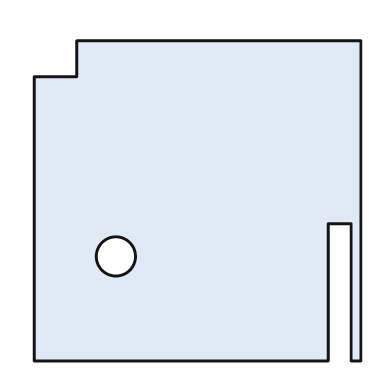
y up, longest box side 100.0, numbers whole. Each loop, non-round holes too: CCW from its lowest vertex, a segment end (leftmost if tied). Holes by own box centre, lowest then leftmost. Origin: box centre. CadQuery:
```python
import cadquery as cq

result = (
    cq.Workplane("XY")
    .moveTo(-50.0, -49.0)
    .lineTo(40.0, -49.0)
    .lineTo(40.0, -7.0)
    .lineTo(47.0, -7.0)
    .lineTo(47.0, -49.0)
    .lineTo(50.0, -49.0)
    .lineTo(50.0, 49.0)
    .lineTo(-37.0, 49.0)
    .lineTo(-37.0, 38.0)
    .lineTo(-50.0, 38.0)
    .close()
    .moveTo(-25.0, -17.0)
    .circle(6.0)
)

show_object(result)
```